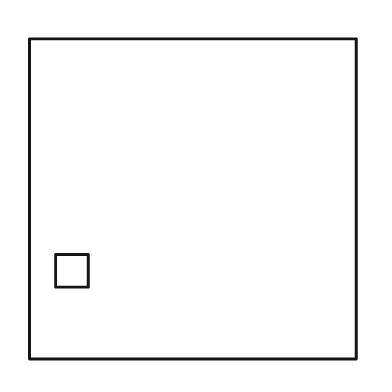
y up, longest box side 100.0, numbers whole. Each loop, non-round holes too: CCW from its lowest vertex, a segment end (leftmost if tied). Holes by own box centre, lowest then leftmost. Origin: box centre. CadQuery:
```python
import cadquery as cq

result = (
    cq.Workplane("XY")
    .moveTo(-50.0, -49.0)
    .lineTo(50.0, -49.0)
    .lineTo(50.0, 49.0)
    .lineTo(-50.0, 49.0)
    .close()
    .moveTo(-42.0, -27.0)
    .lineTo(-32.0, -27.0)
    .lineTo(-32.0, -17.0)
    .lineTo(-42.0, -17.0)
    .close()
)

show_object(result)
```